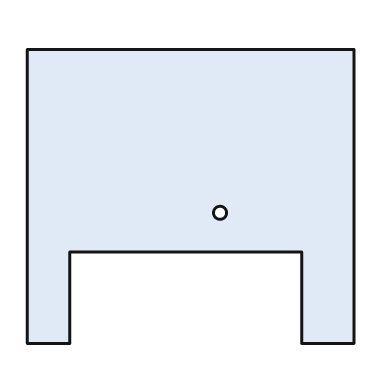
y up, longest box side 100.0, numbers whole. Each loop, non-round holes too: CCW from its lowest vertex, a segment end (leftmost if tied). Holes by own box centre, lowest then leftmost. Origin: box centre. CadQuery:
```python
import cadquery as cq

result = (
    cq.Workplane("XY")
    .moveTo(-50.0, -45.0)
    .lineTo(-37.0, -45.0)
    .lineTo(-37.0, -17.0)
    .lineTo(34.0, -17.0)
    .lineTo(34.0, -45.0)
    .lineTo(50.0, -45.0)
    .lineTo(50.0, 45.0)
    .lineTo(-50.0, 45.0)
    .close()
    .moveTo(9.0, -5.0)
    .circle(2.0)
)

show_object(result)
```